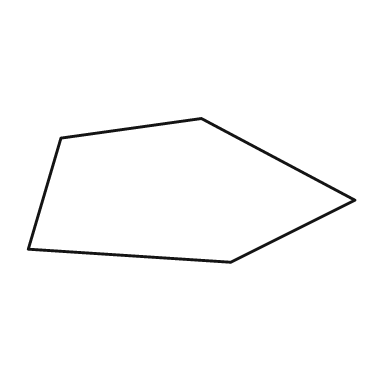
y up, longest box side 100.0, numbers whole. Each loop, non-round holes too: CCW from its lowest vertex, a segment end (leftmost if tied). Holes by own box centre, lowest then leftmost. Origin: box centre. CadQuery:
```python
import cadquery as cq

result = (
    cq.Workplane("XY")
    .moveTo(12.0, -22.0)
    .lineTo(50.0, -3.0)
    .lineTo(3.0, 22.0)
    .lineTo(-40.0, 16.0)
    .lineTo(-50.0, -18.0)
    .close()
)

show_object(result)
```